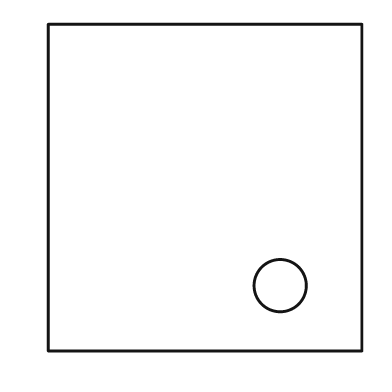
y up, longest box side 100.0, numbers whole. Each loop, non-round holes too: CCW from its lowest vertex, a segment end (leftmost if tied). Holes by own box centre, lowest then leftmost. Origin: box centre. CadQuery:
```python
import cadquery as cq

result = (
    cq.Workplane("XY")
    .moveTo(-48.0, -50.0)
    .lineTo(48.0, -50.0)
    .lineTo(48.0, 50.0)
    .lineTo(-48.0, 50.0)
    .close()
    .moveTo(23.0, -30.0)
    .circle(8.0)
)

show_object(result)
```